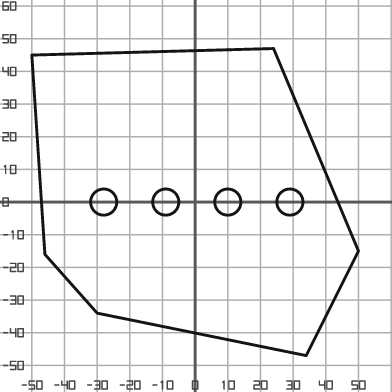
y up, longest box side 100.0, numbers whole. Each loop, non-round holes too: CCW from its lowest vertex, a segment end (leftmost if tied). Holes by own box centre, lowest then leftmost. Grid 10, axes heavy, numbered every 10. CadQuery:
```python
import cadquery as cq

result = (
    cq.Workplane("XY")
    .moveTo(34.0, -47.0)
    .lineTo(50.0, -15.0)
    .lineTo(24.0, 47.0)
    .lineTo(-50.0, 45.0)
    .lineTo(-46.0, -16.0)
    .lineTo(-30.0, -34.0)
    .close()
    .moveTo(-28.0, 0.0)
    .circle(4.0)
    .moveTo(-9.0, 0.0)
    .circle(4.0)
    .moveTo(10.0, 0.0)
    .circle(4.0)
    .moveTo(29.0, 0.0)
    .circle(4.0)
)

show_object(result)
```